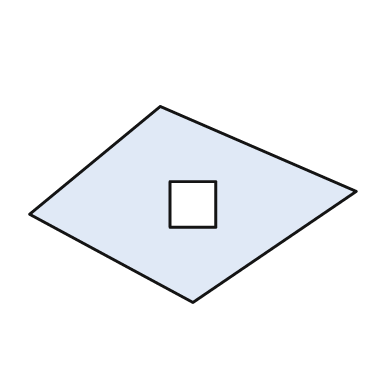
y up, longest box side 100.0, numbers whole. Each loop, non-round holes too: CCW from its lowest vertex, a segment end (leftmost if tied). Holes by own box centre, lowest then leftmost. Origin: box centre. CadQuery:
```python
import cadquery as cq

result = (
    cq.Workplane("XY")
    .moveTo(0.0, -30.0)
    .lineTo(50.0, 4.0)
    .lineTo(-10.0, 30.0)
    .lineTo(-50.0, -3.0)
    .close()
    .moveTo(-7.0, -7.0)
    .lineTo(7.0, -7.0)
    .lineTo(7.0, 7.0)
    .lineTo(-7.0, 7.0)
    .close()
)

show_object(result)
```